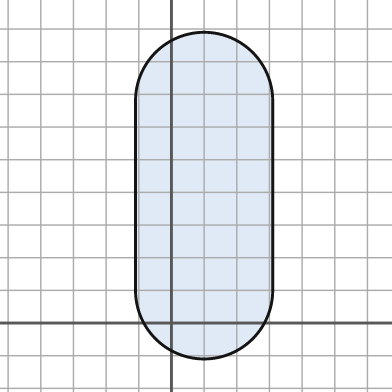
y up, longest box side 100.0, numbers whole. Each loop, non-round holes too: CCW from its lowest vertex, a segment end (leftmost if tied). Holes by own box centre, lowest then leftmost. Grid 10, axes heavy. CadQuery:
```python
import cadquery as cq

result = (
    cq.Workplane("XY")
    .moveTo(-11.0, 10.0)
    .threePointArc((10.0, -11.0), (31.0, 10.0))
    .lineTo(31.0, 68.0)
    .threePointArc((10.0, 89.0), (-11.0, 68.0))
    .close()
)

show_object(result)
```